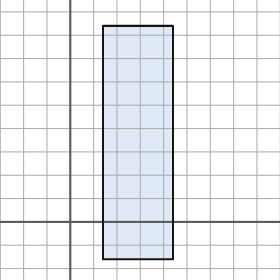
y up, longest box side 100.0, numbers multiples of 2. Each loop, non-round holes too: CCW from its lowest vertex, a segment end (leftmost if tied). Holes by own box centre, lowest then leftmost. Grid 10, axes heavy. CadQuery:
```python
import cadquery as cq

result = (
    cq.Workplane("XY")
    .moveTo(14.0, -16.0)
    .lineTo(44.0, -16.0)
    .lineTo(44.0, 84.0)
    .lineTo(14.0, 84.0)
    .close()
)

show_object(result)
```